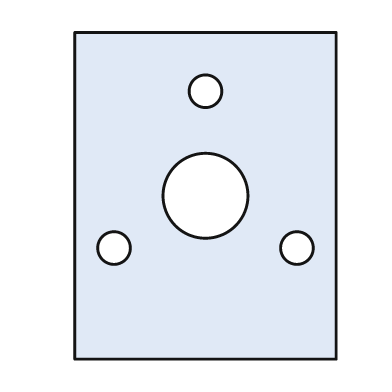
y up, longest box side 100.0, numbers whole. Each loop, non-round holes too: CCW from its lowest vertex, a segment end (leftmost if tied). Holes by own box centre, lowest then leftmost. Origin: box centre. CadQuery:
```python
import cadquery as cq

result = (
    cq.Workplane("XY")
    .moveTo(-40.0, -50.0)
    .lineTo(40.0, -50.0)
    .lineTo(40.0, 50.0)
    .lineTo(-40.0, 50.0)
    .close()
    .moveTo(-28.0, -16.0)
    .circle(5.0)
    .moveTo(28.0, -16.0)
    .circle(5.0)
    .moveTo(0.0, 0.0)
    .circle(13.0)
    .moveTo(0.0, 32.0)
    .circle(5.0)
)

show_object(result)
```